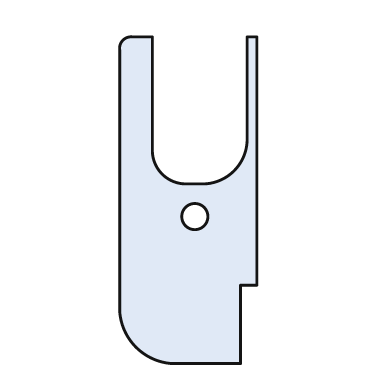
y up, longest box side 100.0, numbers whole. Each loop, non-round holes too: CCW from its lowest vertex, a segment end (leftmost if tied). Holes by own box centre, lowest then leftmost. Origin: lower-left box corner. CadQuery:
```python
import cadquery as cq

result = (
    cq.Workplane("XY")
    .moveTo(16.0, 0.0)
    .lineTo(37.0, 0.0)
    .lineTo(37.0, 24.0)
    .lineTo(42.0, 24.0)
    .lineTo(42.0, 100.0)
    .lineTo(39.0, 100.0)
    .lineTo(39.0, 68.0)
    .threePointArc((35.0, 59.0), (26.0, 55.0))
    .lineTo(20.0, 55.0)
    .threePointArc((13.0, 58.0), (10.0, 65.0))
    .lineTo(10.0, 100.0)
    .lineTo(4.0, 100.0)
    .threePointArc((1.0, 99.0), (0.0, 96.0))
    .lineTo(0.0, 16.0)
    .threePointArc((5.0, 5.0), (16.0, 0.0))
    .close()
    .moveTo(23.0, 45.0)
    .circle(4.0)
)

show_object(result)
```